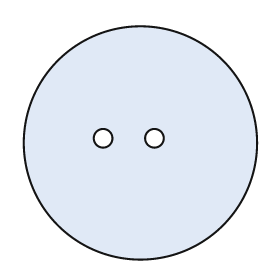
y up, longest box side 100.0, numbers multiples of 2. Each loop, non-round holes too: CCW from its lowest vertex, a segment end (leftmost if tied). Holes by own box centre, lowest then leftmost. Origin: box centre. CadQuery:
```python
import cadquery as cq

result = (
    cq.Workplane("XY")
    .moveTo(0.0, 0.0)
    .circle(50.0)
    .moveTo(-16.0, 2.0)
    .circle(4.0)
    .moveTo(6.0, 2.0)
    .circle(4.0)
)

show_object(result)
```